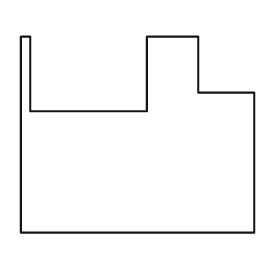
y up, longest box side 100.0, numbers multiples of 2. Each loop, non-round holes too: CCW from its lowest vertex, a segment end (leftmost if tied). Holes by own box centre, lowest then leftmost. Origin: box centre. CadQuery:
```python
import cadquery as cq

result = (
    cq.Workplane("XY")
    .moveTo(-50.0, -42.0)
    .lineTo(50.0, -42.0)
    .lineTo(50.0, 18.0)
    .lineTo(26.0, 18.0)
    .lineTo(26.0, 42.0)
    .lineTo(4.0, 42.0)
    .lineTo(4.0, 10.0)
    .lineTo(-46.0, 10.0)
    .lineTo(-46.0, 42.0)
    .lineTo(-50.0, 42.0)
    .close()
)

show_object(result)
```